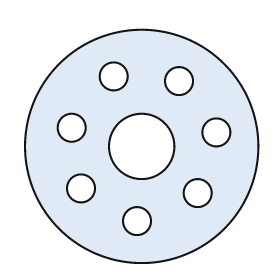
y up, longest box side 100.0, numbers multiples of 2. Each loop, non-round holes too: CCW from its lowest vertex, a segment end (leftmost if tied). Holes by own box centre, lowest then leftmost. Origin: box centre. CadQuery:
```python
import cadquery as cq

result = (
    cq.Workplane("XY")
    .moveTo(0.0, 0.0)
    .circle(50.0)
    .moveTo(-2.0, -32.0)
    .circle(6.0)
    .moveTo(24.0, -20.0)
    .circle(6.0)
    .moveTo(-26.0, -18.0)
    .circle(6.0)
    .moveTo(0.0, 0.0)
    .circle(14.0)
    .moveTo(32.0, 6.0)
    .circle(6.0)
    .moveTo(-30.0, 8.0)
    .circle(6.0)
    .moveTo(16.0, 28.0)
    .circle(6.0)
    .moveTo(-12.0, 30.0)
    .circle(6.0)
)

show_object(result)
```